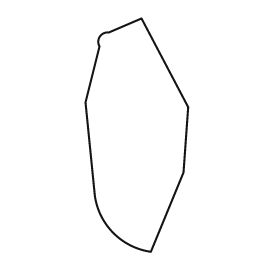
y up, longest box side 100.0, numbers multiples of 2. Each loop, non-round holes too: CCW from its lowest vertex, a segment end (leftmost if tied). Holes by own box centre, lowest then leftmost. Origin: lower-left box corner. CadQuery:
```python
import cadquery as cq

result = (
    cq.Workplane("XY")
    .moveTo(28.0, 0.0)
    .lineTo(42.0, 34.0)
    .lineTo(44.0, 62.0)
    .lineTo(24.0, 100.0)
    .lineTo(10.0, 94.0)
    .threePointArc((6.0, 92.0), (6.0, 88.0))
    .lineTo(0.0, 64.0)
    .lineTo(4.0, 24.0)
    .threePointArc((12.0, 8.0), (28.0, 0.0))
    .close()
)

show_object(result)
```